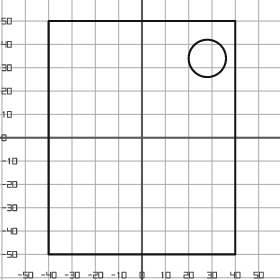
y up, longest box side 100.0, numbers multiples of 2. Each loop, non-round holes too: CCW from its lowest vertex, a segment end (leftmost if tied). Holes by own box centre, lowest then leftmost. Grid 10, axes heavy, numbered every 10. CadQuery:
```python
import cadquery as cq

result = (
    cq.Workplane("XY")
    .moveTo(-40.0, -50.0)
    .lineTo(40.0, -50.0)
    .lineTo(40.0, 50.0)
    .lineTo(-40.0, 50.0)
    .close()
    .moveTo(28.0, 34.0)
    .circle(8.0)
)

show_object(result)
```